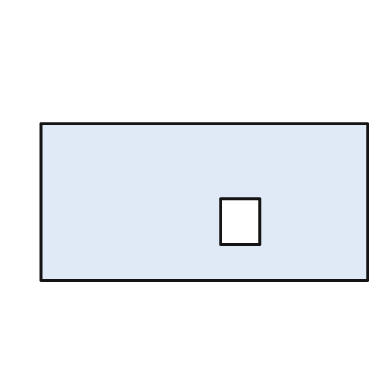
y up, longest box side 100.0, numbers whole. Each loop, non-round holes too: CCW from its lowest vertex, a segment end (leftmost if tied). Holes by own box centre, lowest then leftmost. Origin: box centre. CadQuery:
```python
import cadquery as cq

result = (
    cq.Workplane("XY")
    .moveTo(-50.0, -24.0)
    .lineTo(50.0, -24.0)
    .lineTo(50.0, 24.0)
    .lineTo(-50.0, 24.0)
    .close()
    .moveTo(5.0, -13.0)
    .lineTo(17.0, -13.0)
    .lineTo(17.0, 1.0)
    .lineTo(5.0, 1.0)
    .close()
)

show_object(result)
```